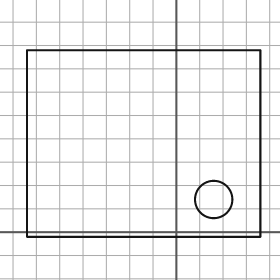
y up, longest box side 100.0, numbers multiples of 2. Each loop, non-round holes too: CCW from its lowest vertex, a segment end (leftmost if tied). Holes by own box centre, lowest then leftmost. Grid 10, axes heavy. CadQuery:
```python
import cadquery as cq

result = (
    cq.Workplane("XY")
    .moveTo(-64.0, -2.0)
    .lineTo(36.0, -2.0)
    .lineTo(36.0, 78.0)
    .lineTo(-64.0, 78.0)
    .close()
    .moveTo(16.0, 14.0)
    .circle(8.0)
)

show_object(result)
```